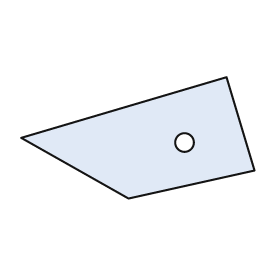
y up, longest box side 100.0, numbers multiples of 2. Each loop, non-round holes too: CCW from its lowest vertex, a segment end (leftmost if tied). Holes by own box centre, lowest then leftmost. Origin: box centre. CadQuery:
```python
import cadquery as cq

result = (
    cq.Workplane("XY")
    .moveTo(-4.0, -26.0)
    .lineTo(50.0, -14.0)
    .lineTo(38.0, 26.0)
    .lineTo(-50.0, 0.0)
    .close()
    .moveTo(20.0, -2.0)
    .circle(4.0)
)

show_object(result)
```